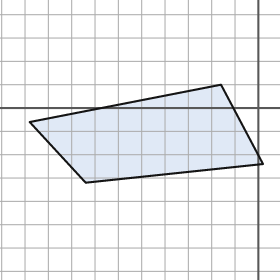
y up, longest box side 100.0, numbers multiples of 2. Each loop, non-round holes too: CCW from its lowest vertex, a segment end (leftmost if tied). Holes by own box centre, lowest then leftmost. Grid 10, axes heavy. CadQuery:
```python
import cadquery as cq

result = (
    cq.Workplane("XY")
    .moveTo(-74.0, -32.0)
    .lineTo(2.0, -24.0)
    .lineTo(-16.0, 10.0)
    .lineTo(-98.0, -6.0)
    .close()
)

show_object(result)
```